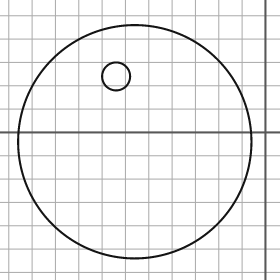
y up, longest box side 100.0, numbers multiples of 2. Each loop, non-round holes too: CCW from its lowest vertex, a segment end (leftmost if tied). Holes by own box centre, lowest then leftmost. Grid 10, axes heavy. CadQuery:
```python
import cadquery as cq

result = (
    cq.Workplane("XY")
    .moveTo(-56.0, -4.0)
    .circle(50.0)
    .moveTo(-64.0, 24.0)
    .circle(6.0)
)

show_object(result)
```